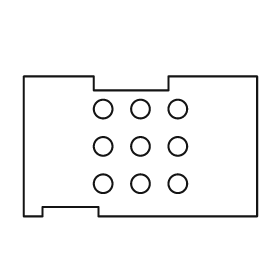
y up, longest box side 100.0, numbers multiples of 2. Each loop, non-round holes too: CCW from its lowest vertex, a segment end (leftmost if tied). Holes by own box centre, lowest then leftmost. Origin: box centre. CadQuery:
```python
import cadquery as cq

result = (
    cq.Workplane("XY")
    .moveTo(-50.0, -30.0)
    .lineTo(-42.0, -30.0)
    .lineTo(-42.0, -26.0)
    .lineTo(-18.0, -26.0)
    .lineTo(-18.0, -30.0)
    .lineTo(50.0, -30.0)
    .lineTo(50.0, 30.0)
    .lineTo(12.0, 30.0)
    .lineTo(12.0, 24.0)
    .lineTo(-20.0, 24.0)
    .lineTo(-20.0, 30.0)
    .lineTo(-50.0, 30.0)
    .close()
    .moveTo(-16.0, -16.0)
    .circle(4.0)
    .moveTo(0.0, -16.0)
    .circle(4.0)
    .moveTo(16.0, -16.0)
    .circle(4.0)
    .moveTo(-16.0, 0.0)
    .circle(4.0)
    .moveTo(0.0, 0.0)
    .circle(4.0)
    .moveTo(16.0, 0.0)
    .circle(4.0)
    .moveTo(-16.0, 16.0)
    .circle(4.0)
    .moveTo(0.0, 16.0)
    .circle(4.0)
    .moveTo(16.0, 16.0)
    .circle(4.0)
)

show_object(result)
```